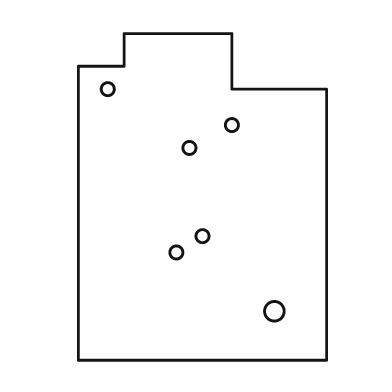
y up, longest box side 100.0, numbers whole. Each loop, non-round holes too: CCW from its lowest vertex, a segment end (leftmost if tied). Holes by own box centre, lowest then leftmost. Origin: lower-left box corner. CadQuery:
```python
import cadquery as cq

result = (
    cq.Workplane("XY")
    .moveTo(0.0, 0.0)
    .lineTo(76.0, 0.0)
    .lineTo(76.0, 83.0)
    .lineTo(47.0, 83.0)
    .lineTo(47.0, 100.0)
    .lineTo(14.0, 100.0)
    .lineTo(14.0, 90.0)
    .lineTo(0.0, 90.0)
    .close()
    .moveTo(60.0, 15.0)
    .circle(3.0)
    .moveTo(30.0, 33.0)
    .circle(2.0)
    .moveTo(38.0, 38.0)
    .circle(2.0)
    .moveTo(34.0, 65.0)
    .circle(2.0)
    .moveTo(47.0, 72.0)
    .circle(2.0)
    .moveTo(9.0, 83.0)
    .circle(2.0)
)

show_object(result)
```